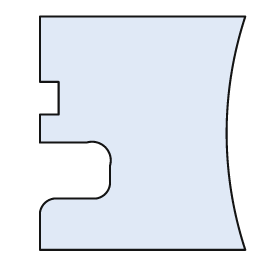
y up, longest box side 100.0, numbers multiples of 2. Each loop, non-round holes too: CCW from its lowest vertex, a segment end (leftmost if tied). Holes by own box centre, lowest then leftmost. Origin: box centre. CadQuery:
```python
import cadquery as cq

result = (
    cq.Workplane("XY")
    .moveTo(-44.0, -50.0)
    .lineTo(44.0, -50.0)
    .threePointArc((36.0, 0.0), (44.0, 50.0))
    .lineTo(-44.0, 50.0)
    .lineTo(-44.0, 22.0)
    .lineTo(-36.0, 22.0)
    .lineTo(-36.0, 8.0)
    .lineTo(-44.0, 8.0)
    .lineTo(-44.0, -4.0)
    .lineTo(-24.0, -4.0)
    .threePointArc((-16.0, -6.0), (-14.0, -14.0))
    .lineTo(-14.0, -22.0)
    .threePointArc((-16.0, -26.0), (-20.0, -28.0))
    .lineTo(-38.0, -28.0)
    .threePointArc((-42.0, -30.0), (-44.0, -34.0))
    .close()
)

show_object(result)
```